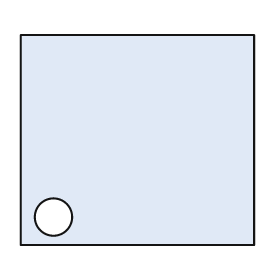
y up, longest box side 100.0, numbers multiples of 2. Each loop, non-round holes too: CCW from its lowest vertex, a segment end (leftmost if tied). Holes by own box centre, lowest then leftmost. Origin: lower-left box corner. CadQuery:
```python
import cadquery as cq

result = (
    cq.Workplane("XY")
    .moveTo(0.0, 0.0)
    .lineTo(100.0, 0.0)
    .lineTo(100.0, 90.0)
    .lineTo(0.0, 90.0)
    .close()
    .moveTo(14.0, 12.0)
    .circle(8.0)
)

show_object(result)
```